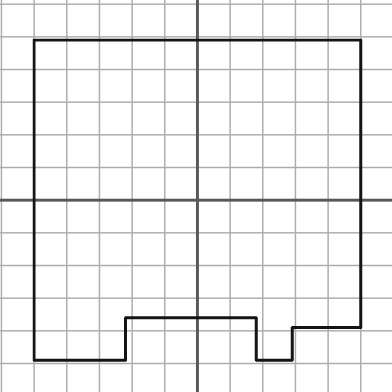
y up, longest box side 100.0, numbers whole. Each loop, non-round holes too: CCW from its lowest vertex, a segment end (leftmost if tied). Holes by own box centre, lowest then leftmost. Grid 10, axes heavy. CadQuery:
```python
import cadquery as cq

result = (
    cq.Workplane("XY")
    .moveTo(-50.0, -49.0)
    .lineTo(-22.0, -49.0)
    .lineTo(-22.0, -36.0)
    .lineTo(18.0, -36.0)
    .lineTo(18.0, -49.0)
    .lineTo(29.0, -49.0)
    .lineTo(29.0, -39.0)
    .lineTo(50.0, -39.0)
    .lineTo(50.0, 49.0)
    .lineTo(-50.0, 49.0)
    .close()
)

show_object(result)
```